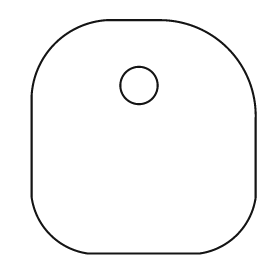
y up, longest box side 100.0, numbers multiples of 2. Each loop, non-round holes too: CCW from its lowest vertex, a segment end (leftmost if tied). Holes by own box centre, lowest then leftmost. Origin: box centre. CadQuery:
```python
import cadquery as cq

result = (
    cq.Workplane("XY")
    .moveTo(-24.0, -50.0)
    .lineTo(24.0, -50.0)
    .threePointArc((40.0, -42.0), (48.0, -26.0))
    .lineTo(48.0, 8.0)
    .threePointArc((36.0, 38.0), (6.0, 50.0))
    .lineTo(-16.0, 50.0)
    .threePointArc((-38.0, 40.0), (-48.0, 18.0))
    .lineTo(-48.0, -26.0)
    .threePointArc((-40.0, -42.0), (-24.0, -50.0))
    .close()
    .moveTo(-2.0, 22.0)
    .circle(8.0)
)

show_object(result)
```